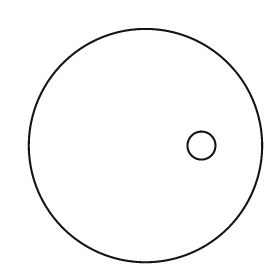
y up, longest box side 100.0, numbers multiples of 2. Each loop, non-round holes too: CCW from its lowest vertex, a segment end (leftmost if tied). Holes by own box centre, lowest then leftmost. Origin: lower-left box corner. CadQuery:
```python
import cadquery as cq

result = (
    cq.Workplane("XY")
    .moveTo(50.0, 50.0)
    .circle(50.0)
    .moveTo(74.0, 50.0)
    .circle(6.0)
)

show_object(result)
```